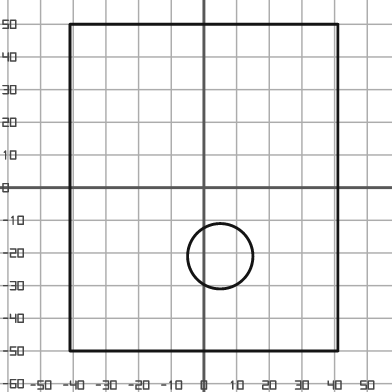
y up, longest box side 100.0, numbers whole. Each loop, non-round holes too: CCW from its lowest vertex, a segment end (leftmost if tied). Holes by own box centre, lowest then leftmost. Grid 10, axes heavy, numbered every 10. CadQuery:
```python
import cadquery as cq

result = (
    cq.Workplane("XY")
    .moveTo(-41.0, -50.0)
    .lineTo(41.0, -50.0)
    .lineTo(41.0, 50.0)
    .lineTo(-41.0, 50.0)
    .close()
    .moveTo(5.0, -21.0)
    .circle(10.0)
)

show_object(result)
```